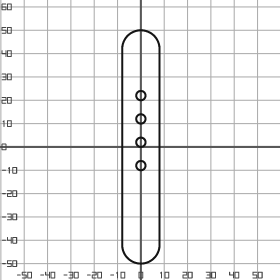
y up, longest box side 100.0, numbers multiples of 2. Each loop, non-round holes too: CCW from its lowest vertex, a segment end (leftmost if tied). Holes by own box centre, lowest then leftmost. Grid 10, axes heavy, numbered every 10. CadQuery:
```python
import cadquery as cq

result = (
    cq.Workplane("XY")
    .moveTo(-8.0, -42.0)
    .threePointArc((0.0, -50.0), (8.0, -42.0))
    .lineTo(8.0, 42.0)
    .threePointArc((0.0, 50.0), (-8.0, 42.0))
    .close()
    .moveTo(0.0, -8.0)
    .circle(2.0)
    .moveTo(0.0, 2.0)
    .circle(2.0)
    .moveTo(0.0, 12.0)
    .circle(2.0)
    .moveTo(0.0, 22.0)
    .circle(2.0)
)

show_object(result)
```